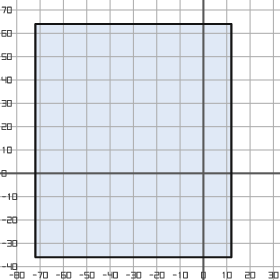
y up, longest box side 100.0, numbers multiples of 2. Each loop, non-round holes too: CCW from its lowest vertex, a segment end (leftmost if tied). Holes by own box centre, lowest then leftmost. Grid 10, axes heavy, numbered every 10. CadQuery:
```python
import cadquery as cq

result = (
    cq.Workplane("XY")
    .moveTo(-72.0, -36.0)
    .lineTo(12.0, -36.0)
    .lineTo(12.0, 64.0)
    .lineTo(-72.0, 64.0)
    .close()
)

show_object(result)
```